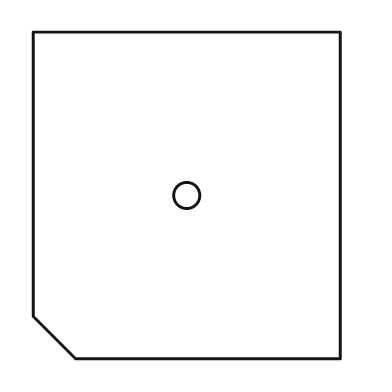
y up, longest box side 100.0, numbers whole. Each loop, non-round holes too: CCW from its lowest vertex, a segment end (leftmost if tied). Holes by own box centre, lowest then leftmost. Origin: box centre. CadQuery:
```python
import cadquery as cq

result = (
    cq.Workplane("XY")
    .moveTo(-34.0, -50.0)
    .lineTo(47.0, -50.0)
    .lineTo(47.0, 50.0)
    .lineTo(-47.0, 50.0)
    .lineTo(-47.0, -37.0)
    .close()
    .moveTo(0.0, 0.0)
    .circle(4.0)
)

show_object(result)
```